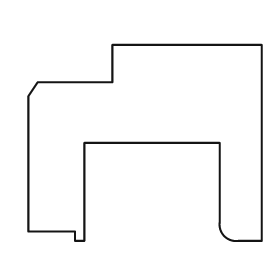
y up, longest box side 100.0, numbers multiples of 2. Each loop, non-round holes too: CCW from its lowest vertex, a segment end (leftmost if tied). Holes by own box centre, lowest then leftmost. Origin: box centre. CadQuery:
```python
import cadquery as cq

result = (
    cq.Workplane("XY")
    .moveTo(-30.0, -42.0)
    .lineTo(-26.0, -42.0)
    .lineTo(-26.0, 0.0)
    .lineTo(32.0, 0.0)
    .lineTo(32.0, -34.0)
    .threePointArc((34.0, -40.0), (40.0, -42.0))
    .lineTo(50.0, -42.0)
    .lineTo(50.0, 42.0)
    .lineTo(-14.0, 42.0)
    .lineTo(-14.0, 26.0)
    .lineTo(-46.0, 26.0)
    .lineTo(-50.0, 20.0)
    .lineTo(-50.0, -38.0)
    .lineTo(-30.0, -38.0)
    .close()
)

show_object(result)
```